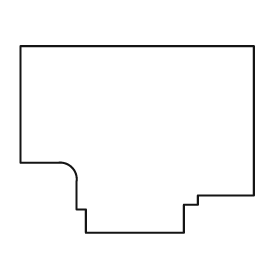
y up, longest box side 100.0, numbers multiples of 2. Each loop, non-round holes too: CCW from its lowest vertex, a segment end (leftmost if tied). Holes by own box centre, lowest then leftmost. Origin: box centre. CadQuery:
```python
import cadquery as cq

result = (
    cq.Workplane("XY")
    .moveTo(-22.0, -40.0)
    .lineTo(20.0, -40.0)
    .lineTo(20.0, -28.0)
    .lineTo(26.0, -28.0)
    .lineTo(26.0, -24.0)
    .lineTo(50.0, -24.0)
    .lineTo(50.0, 40.0)
    .lineTo(-50.0, 40.0)
    .lineTo(-50.0, -10.0)
    .lineTo(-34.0, -10.0)
    .threePointArc((-28.0, -12.0), (-26.0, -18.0))
    .lineTo(-26.0, -30.0)
    .lineTo(-22.0, -30.0)
    .close()
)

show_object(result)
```